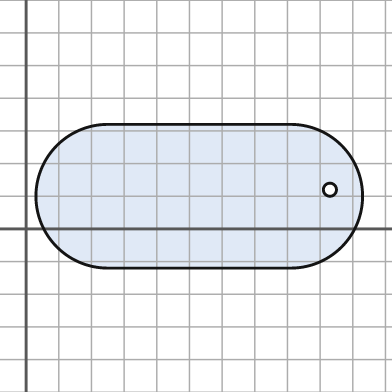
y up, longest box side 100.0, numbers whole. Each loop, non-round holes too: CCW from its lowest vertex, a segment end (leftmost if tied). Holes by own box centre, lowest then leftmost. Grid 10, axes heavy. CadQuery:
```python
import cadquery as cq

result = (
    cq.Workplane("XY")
    .moveTo(25.0, -12.0)
    .lineTo(81.0, -12.0)
    .threePointArc((103.0, 10.0), (81.0, 32.0))
    .lineTo(25.0, 32.0)
    .threePointArc((3.0, 10.0), (25.0, -12.0))
    .close()
    .moveTo(93.0, 12.0)
    .circle(2.0)
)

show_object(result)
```